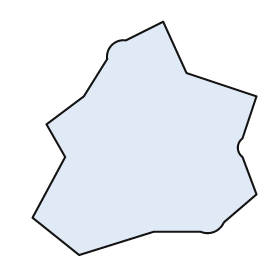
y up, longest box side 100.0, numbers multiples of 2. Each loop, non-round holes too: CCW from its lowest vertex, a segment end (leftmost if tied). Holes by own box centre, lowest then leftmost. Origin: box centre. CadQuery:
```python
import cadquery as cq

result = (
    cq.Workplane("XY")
    .moveTo(-28.0, -50.0)
    .lineTo(4.0, -40.0)
    .lineTo(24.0, -40.0)
    .threePointArc((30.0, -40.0), (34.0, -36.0))
    .lineTo(48.0, -24.0)
    .lineTo(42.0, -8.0)
    .threePointArc((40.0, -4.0), (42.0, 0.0))
    .lineTo(48.0, 18.0)
    .lineTo(18.0, 28.0)
    .lineTo(8.0, 50.0)
    .lineTo(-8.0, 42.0)
    .threePointArc((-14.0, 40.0), (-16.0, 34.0))
    .lineTo(-26.0, 18.0)
    .lineTo(-42.0, 6.0)
    .lineTo(-34.0, -8.0)
    .lineTo(-48.0, -34.0)
    .close()
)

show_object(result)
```